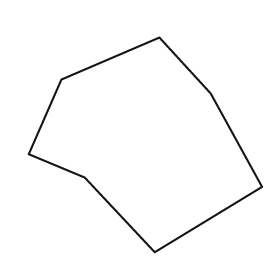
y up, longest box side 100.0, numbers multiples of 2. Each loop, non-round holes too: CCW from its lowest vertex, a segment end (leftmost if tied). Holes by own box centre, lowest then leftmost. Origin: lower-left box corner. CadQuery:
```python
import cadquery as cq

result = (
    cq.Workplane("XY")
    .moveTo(54.0, 0.0)
    .lineTo(100.0, 28.0)
    .lineTo(78.0, 68.0)
    .lineTo(56.0, 92.0)
    .lineTo(14.0, 74.0)
    .lineTo(0.0, 42.0)
    .lineTo(24.0, 32.0)
    .close()
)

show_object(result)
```